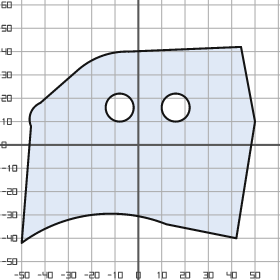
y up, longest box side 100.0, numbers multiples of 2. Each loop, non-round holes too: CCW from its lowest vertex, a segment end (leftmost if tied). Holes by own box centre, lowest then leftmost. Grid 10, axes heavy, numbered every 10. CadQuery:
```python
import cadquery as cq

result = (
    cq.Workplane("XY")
    .moveTo(-50.0, -42.0)
    .threePointArc((-20.0, -30.0), (12.0, -34.0))
    .lineTo(42.0, -40.0)
    .lineTo(50.0, 10.0)
    .lineTo(44.0, 42.0)
    .lineTo(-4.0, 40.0)
    .threePointArc((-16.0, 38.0), (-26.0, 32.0))
    .lineTo(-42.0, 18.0)
    .threePointArc((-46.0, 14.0), (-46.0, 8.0))
    .close()
    .moveTo(-8.0, 16.0)
    .circle(6.0)
    .moveTo(16.0, 16.0)
    .circle(6.0)
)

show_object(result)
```